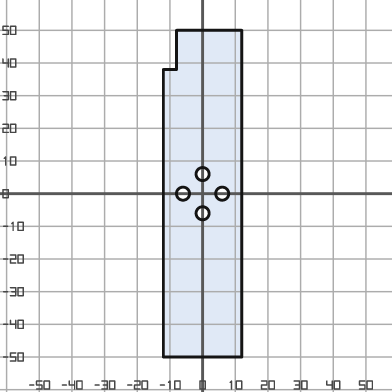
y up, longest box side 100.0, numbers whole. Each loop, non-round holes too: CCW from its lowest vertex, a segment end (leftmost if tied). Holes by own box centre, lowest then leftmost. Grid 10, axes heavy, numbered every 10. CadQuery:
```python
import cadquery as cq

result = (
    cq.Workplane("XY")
    .moveTo(-12.0, -50.0)
    .lineTo(12.0, -50.0)
    .lineTo(12.0, 50.0)
    .lineTo(-8.0, 50.0)
    .lineTo(-8.0, 38.0)
    .lineTo(-12.0, 38.0)
    .close()
    .moveTo(0.0, -6.0)
    .circle(2.0)
    .moveTo(-6.0, 0.0)
    .circle(2.0)
    .moveTo(6.0, 0.0)
    .circle(2.0)
    .moveTo(0.0, 6.0)
    .circle(2.0)
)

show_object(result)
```